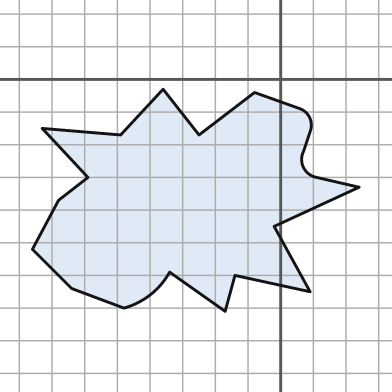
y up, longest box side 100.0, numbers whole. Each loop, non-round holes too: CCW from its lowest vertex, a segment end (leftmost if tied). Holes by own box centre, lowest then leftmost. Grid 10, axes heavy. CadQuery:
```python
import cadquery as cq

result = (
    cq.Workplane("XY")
    .moveTo(-17.0, -71.0)
    .lineTo(-14.0, -60.0)
    .lineTo(9.0, -65.0)
    .lineTo(-2.0, -45.0)
    .lineTo(24.0, -33.0)
    .lineTo(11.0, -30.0)
    .threePointArc((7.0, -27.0), (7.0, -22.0))
    .lineTo(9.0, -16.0)
    .threePointArc((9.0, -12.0), (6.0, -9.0))
    .lineTo(-8.0, -4.0)
    .lineTo(-25.0, -17.0)
    .lineTo(-36.0, -3.0)
    .lineTo(-49.0, -17.0)
    .lineTo(-73.0, -15.0)
    .lineTo(-59.0, -30.0)
    .lineTo(-68.0, -37.0)
    .lineTo(-76.0, -52.0)
    .lineTo(-64.0, -64.0)
    .lineTo(-48.0, -70.0)
    .threePointArc((-40.0, -66.0), (-34.0, -59.0))
    .close()
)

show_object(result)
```